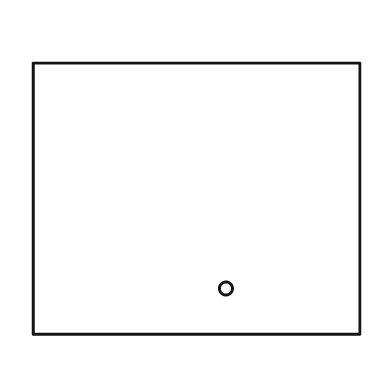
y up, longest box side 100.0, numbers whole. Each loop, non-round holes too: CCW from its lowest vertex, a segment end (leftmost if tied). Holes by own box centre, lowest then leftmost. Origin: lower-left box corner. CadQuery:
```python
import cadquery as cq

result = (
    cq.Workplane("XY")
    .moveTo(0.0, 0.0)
    .lineTo(100.0, 0.0)
    .lineTo(100.0, 83.0)
    .lineTo(0.0, 83.0)
    .close()
    .moveTo(59.0, 14.0)
    .circle(2.0)
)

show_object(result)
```